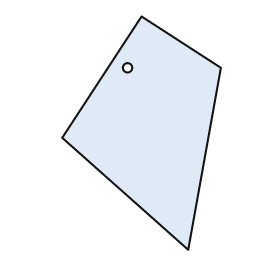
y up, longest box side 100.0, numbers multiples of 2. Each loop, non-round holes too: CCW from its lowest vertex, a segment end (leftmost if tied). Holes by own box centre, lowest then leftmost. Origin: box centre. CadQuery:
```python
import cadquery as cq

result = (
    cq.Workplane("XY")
    .moveTo(20.0, -50.0)
    .lineTo(34.0, 28.0)
    .lineTo(0.0, 50.0)
    .lineTo(-34.0, -2.0)
    .close()
    .moveTo(-6.0, 28.0)
    .circle(2.0)
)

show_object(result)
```